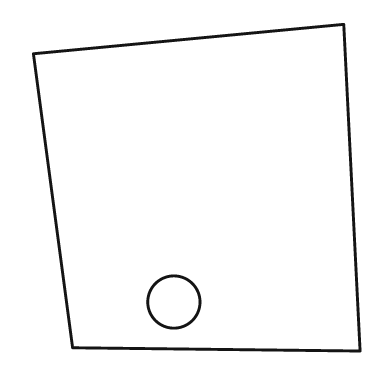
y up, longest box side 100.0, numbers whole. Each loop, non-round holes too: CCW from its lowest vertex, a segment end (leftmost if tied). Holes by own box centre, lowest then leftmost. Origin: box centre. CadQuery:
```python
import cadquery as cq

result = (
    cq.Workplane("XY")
    .moveTo(50.0, -50.0)
    .lineTo(45.0, 50.0)
    .lineTo(-50.0, 41.0)
    .lineTo(-38.0, -49.0)
    .close()
    .moveTo(-7.0, -35.0)
    .circle(8.0)
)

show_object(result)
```